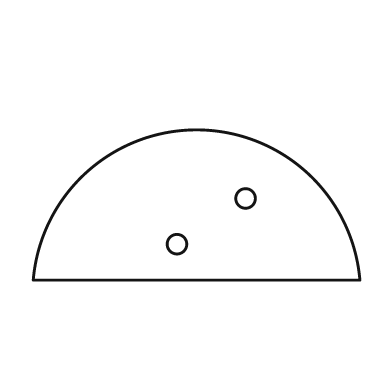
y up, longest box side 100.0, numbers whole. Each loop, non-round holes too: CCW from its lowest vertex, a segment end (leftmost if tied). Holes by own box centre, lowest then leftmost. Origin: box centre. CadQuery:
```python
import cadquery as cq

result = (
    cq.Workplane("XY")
    .moveTo(-50.0, -23.0)
    .lineTo(50.0, -23.0)
    .threePointArc((0.0, 23.0), (-50.0, -23.0))
    .close()
    .moveTo(-6.0, -12.0)
    .circle(3.0)
    .moveTo(15.0, 2.0)
    .circle(3.0)
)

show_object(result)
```